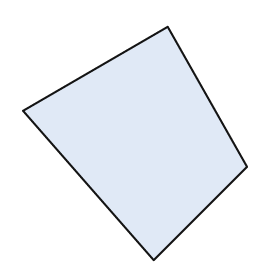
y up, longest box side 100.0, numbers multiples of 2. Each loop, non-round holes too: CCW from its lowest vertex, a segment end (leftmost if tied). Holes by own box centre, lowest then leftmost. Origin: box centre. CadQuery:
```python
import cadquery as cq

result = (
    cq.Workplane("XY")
    .moveTo(8.0, -50.0)
    .lineTo(48.0, -10.0)
    .lineTo(14.0, 50.0)
    .lineTo(-48.0, 14.0)
    .close()
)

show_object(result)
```